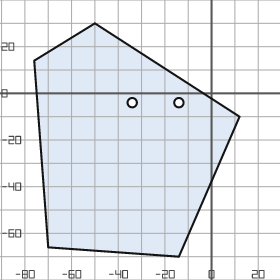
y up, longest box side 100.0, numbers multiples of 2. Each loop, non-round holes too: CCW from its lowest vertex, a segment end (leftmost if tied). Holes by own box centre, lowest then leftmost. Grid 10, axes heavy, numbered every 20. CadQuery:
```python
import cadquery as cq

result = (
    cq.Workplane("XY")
    .moveTo(-14.0, -70.0)
    .lineTo(12.0, -10.0)
    .lineTo(-50.0, 30.0)
    .lineTo(-76.0, 14.0)
    .lineTo(-70.0, -66.0)
    .close()
    .moveTo(-34.0, -4.0)
    .circle(2.0)
    .moveTo(-14.0, -4.0)
    .circle(2.0)
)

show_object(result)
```